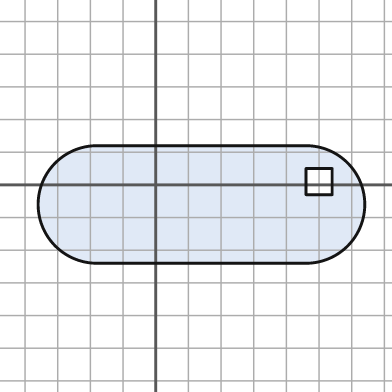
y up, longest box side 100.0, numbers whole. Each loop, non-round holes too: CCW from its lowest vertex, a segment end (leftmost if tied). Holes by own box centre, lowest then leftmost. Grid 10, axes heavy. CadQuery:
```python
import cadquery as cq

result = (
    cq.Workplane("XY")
    .moveTo(-18.0, -24.0)
    .lineTo(46.0, -24.0)
    .threePointArc((64.0, -6.0), (46.0, 12.0))
    .lineTo(-18.0, 12.0)
    .threePointArc((-36.0, -6.0), (-18.0, -24.0))
    .close()
    .moveTo(46.0, -3.0)
    .lineTo(54.0, -3.0)
    .lineTo(54.0, 5.0)
    .lineTo(46.0, 5.0)
    .close()
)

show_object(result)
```